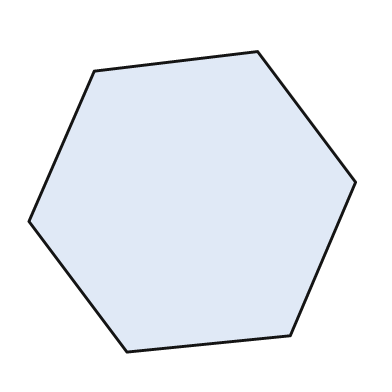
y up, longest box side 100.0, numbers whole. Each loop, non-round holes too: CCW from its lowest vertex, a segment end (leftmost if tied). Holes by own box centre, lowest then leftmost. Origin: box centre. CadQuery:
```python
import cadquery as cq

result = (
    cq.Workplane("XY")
    .moveTo(-20.0, -46.0)
    .lineTo(30.0, -41.0)
    .lineTo(50.0, 6.0)
    .lineTo(20.0, 46.0)
    .lineTo(-30.0, 40.0)
    .lineTo(-50.0, -6.0)
    .close()
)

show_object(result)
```